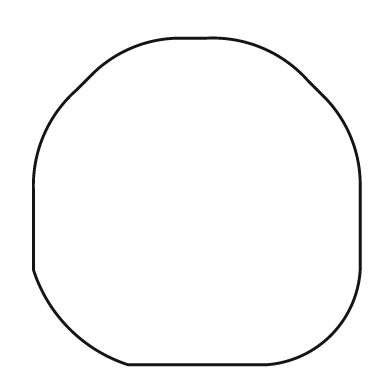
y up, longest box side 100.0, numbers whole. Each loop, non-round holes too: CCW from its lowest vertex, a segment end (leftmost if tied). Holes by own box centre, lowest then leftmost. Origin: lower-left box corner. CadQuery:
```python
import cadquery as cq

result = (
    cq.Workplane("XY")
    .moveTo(29.0, 0.0)
    .lineTo(71.0, 0.0)
    .threePointArc((91.0, 9.0), (100.0, 29.0))
    .lineTo(100.0, 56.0)
    .threePointArc((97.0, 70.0), (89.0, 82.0))
    .lineTo(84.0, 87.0)
    .threePointArc((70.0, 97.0), (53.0, 100.0))
    .lineTo(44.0, 100.0)
    .threePointArc((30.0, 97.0), (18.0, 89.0))
    .lineTo(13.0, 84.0)
    .threePointArc((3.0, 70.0), (0.0, 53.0))
    .lineTo(0.0, 29.0)
    .threePointArc((11.0, 11.0), (29.0, 0.0))
    .close()
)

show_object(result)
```